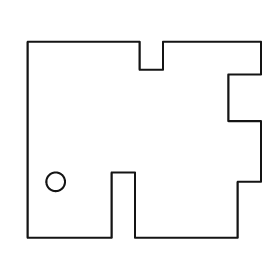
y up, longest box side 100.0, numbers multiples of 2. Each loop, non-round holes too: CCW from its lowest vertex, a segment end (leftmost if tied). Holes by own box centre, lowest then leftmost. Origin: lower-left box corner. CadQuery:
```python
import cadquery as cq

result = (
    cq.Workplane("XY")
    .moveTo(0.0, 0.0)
    .lineTo(36.0, 0.0)
    .lineTo(36.0, 28.0)
    .lineTo(46.0, 28.0)
    .lineTo(46.0, 0.0)
    .lineTo(90.0, 0.0)
    .lineTo(90.0, 24.0)
    .lineTo(100.0, 24.0)
    .lineTo(100.0, 50.0)
    .lineTo(86.0, 50.0)
    .lineTo(86.0, 70.0)
    .lineTo(100.0, 70.0)
    .lineTo(100.0, 84.0)
    .lineTo(58.0, 84.0)
    .lineTo(58.0, 72.0)
    .lineTo(48.0, 72.0)
    .lineTo(48.0, 84.0)
    .lineTo(0.0, 84.0)
    .close()
    .moveTo(12.0, 24.0)
    .circle(4.0)
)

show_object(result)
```